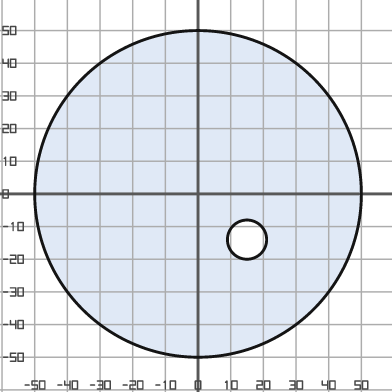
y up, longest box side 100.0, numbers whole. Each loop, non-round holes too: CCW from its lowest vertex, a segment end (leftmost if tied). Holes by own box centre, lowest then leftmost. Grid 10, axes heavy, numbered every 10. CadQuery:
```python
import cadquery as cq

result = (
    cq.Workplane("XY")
    .moveTo(0.0, 0.0)
    .circle(50.0)
    .moveTo(15.0, -14.0)
    .circle(6.0)
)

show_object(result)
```